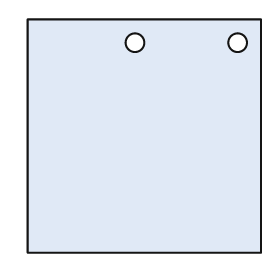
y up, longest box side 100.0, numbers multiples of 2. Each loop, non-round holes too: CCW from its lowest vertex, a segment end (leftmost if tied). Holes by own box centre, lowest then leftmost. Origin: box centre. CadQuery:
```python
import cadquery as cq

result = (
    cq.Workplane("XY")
    .moveTo(-50.0, -50.0)
    .lineTo(50.0, -50.0)
    .lineTo(50.0, 50.0)
    .lineTo(-50.0, 50.0)
    .close()
    .moveTo(-4.0, 40.0)
    .circle(4.0)
    .moveTo(40.0, 40.0)
    .circle(4.0)
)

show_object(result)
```